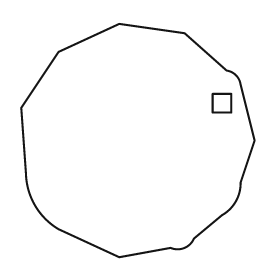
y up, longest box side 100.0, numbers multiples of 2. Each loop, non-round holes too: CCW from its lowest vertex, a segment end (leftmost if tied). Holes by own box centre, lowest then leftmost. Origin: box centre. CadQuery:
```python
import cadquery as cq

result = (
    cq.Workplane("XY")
    .moveTo(-8.0, -50.0)
    .lineTo(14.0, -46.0)
    .threePointArc((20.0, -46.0), (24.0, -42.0))
    .lineTo(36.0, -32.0)
    .threePointArc((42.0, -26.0), (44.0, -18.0))
    .lineTo(50.0, 0.0)
    .lineTo(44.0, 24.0)
    .threePointArc((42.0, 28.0), (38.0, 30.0))
    .lineTo(20.0, 46.0)
    .lineTo(-8.0, 50.0)
    .lineTo(-34.0, 38.0)
    .lineTo(-50.0, 14.0)
    .lineTo(-48.0, -14.0)
    .threePointArc((-44.0, -28.0), (-34.0, -38.0))
    .close()
    .moveTo(32.0, 12.0)
    .lineTo(40.0, 12.0)
    .lineTo(40.0, 20.0)
    .lineTo(32.0, 20.0)
    .close()
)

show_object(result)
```